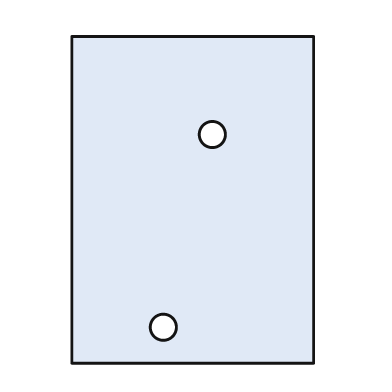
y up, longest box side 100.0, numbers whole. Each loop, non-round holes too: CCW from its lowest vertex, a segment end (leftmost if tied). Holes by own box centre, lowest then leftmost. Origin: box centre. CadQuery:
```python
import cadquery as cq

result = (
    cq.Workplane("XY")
    .moveTo(-37.0, -50.0)
    .lineTo(37.0, -50.0)
    .lineTo(37.0, 50.0)
    .lineTo(-37.0, 50.0)
    .close()
    .moveTo(-9.0, -39.0)
    .circle(4.0)
    .moveTo(6.0, 20.0)
    .circle(4.0)
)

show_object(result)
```